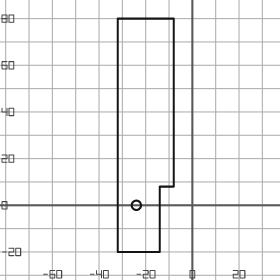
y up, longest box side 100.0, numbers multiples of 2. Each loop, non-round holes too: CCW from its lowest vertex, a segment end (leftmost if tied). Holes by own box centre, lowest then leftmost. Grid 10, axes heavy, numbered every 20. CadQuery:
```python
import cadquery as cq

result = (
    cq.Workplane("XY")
    .moveTo(-32.0, -20.0)
    .lineTo(-14.0, -20.0)
    .lineTo(-14.0, 8.0)
    .lineTo(-8.0, 8.0)
    .lineTo(-8.0, 80.0)
    .lineTo(-32.0, 80.0)
    .close()
    .moveTo(-24.0, 0.0)
    .circle(2.0)
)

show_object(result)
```